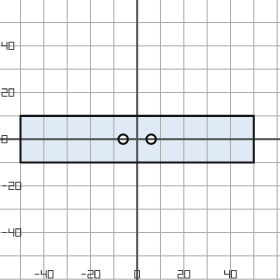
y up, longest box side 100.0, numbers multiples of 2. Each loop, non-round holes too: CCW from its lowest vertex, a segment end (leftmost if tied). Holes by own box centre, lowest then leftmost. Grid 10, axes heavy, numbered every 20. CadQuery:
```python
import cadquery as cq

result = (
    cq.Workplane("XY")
    .moveTo(-50.0, -10.0)
    .lineTo(50.0, -10.0)
    .lineTo(50.0, 10.0)
    .lineTo(-50.0, 10.0)
    .close()
    .moveTo(-6.0, 0.0)
    .circle(2.0)
    .moveTo(6.0, 0.0)
    .circle(2.0)
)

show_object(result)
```